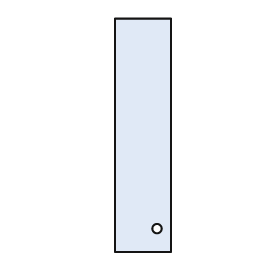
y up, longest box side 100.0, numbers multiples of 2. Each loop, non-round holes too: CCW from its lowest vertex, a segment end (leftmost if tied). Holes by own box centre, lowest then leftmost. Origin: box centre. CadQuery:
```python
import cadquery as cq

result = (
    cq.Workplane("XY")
    .moveTo(-12.0, -50.0)
    .lineTo(12.0, -50.0)
    .lineTo(12.0, 50.0)
    .lineTo(-12.0, 50.0)
    .close()
    .moveTo(6.0, -40.0)
    .circle(2.0)
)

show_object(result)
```